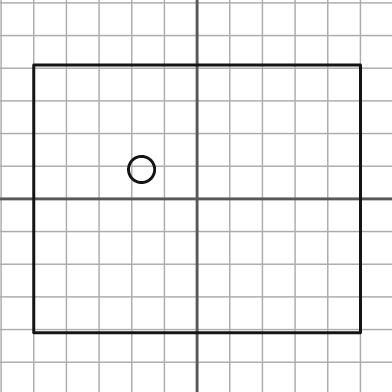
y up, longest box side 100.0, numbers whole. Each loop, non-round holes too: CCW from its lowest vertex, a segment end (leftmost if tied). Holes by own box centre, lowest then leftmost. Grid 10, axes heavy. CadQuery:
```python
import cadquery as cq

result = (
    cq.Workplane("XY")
    .moveTo(-50.0, -41.0)
    .lineTo(50.0, -41.0)
    .lineTo(50.0, 41.0)
    .lineTo(-50.0, 41.0)
    .close()
    .moveTo(-17.0, 9.0)
    .circle(4.0)
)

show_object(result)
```